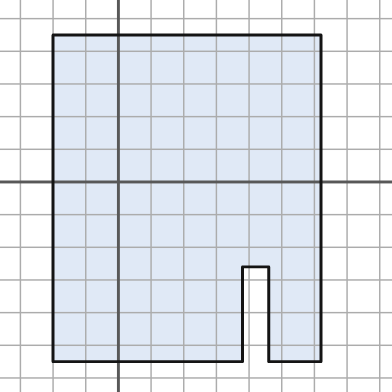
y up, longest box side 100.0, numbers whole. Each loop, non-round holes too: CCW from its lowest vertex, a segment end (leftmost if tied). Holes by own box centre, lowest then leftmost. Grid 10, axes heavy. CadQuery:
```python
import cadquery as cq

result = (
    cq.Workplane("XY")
    .moveTo(-20.0, -55.0)
    .lineTo(38.0, -55.0)
    .lineTo(38.0, -26.0)
    .lineTo(46.0, -26.0)
    .lineTo(46.0, -55.0)
    .lineTo(62.0, -55.0)
    .lineTo(62.0, 45.0)
    .lineTo(-20.0, 45.0)
    .close()
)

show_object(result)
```